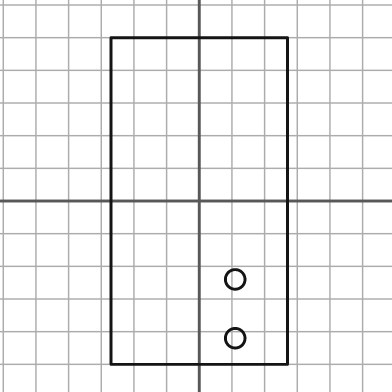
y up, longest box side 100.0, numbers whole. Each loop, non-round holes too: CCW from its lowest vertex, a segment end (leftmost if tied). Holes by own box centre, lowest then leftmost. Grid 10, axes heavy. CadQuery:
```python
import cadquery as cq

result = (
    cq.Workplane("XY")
    .moveTo(-27.0, -50.0)
    .lineTo(27.0, -50.0)
    .lineTo(27.0, 50.0)
    .lineTo(-27.0, 50.0)
    .close()
    .moveTo(11.0, -42.0)
    .circle(3.0)
    .moveTo(11.0, -24.0)
    .circle(3.0)
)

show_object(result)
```